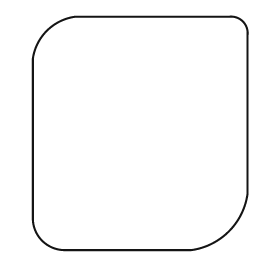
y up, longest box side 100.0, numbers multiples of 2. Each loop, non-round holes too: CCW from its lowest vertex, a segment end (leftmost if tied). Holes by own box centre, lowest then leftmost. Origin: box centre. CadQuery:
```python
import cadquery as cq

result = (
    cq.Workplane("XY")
    .moveTo(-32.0, -50.0)
    .lineTo(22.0, -50.0)
    .threePointArc((38.0, -42.0), (46.0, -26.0))
    .lineTo(46.0, 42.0)
    .threePointArc((44.0, 48.0), (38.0, 50.0))
    .lineTo(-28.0, 50.0)
    .threePointArc((-40.0, 44.0), (-46.0, 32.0))
    .lineTo(-46.0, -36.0)
    .threePointArc((-42.0, -46.0), (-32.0, -50.0))
    .close()
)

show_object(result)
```